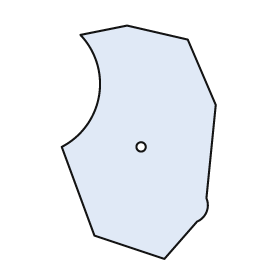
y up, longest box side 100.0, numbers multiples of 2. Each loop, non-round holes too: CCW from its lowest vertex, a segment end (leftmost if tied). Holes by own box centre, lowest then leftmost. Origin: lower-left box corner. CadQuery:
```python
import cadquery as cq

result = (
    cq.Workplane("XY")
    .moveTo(44.0, 0.0)
    .lineTo(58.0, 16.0)
    .threePointArc((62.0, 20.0), (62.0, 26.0))
    .lineTo(66.0, 66.0)
    .lineTo(54.0, 94.0)
    .lineTo(28.0, 100.0)
    .lineTo(8.0, 96.0)
    .threePointArc((16.0, 70.0), (0.0, 48.0))
    .lineTo(14.0, 10.0)
    .close()
    .moveTo(34.0, 48.0)
    .circle(2.0)
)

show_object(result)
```